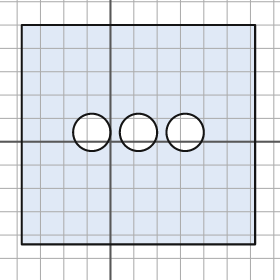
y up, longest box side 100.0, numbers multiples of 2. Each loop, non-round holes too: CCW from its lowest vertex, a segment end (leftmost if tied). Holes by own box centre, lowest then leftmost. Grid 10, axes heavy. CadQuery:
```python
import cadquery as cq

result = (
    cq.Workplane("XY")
    .moveTo(-38.0, -44.0)
    .lineTo(62.0, -44.0)
    .lineTo(62.0, 50.0)
    .lineTo(-38.0, 50.0)
    .close()
    .moveTo(-8.0, 4.0)
    .circle(8.0)
    .moveTo(12.0, 4.0)
    .circle(8.0)
    .moveTo(32.0, 4.0)
    .circle(8.0)
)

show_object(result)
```